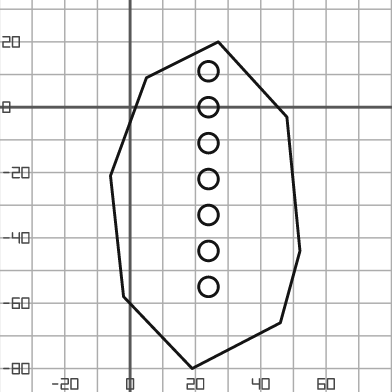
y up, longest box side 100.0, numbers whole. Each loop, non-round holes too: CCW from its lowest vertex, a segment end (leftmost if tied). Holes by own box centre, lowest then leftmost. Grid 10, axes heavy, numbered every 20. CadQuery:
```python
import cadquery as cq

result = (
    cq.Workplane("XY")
    .moveTo(19.0, -80.0)
    .lineTo(46.0, -66.0)
    .lineTo(52.0, -44.0)
    .lineTo(48.0, -3.0)
    .lineTo(27.0, 20.0)
    .lineTo(5.0, 9.0)
    .lineTo(-6.0, -21.0)
    .lineTo(-2.0, -58.0)
    .close()
    .moveTo(24.0, -55.0)
    .circle(3.0)
    .moveTo(24.0, -44.0)
    .circle(3.0)
    .moveTo(24.0, -33.0)
    .circle(3.0)
    .moveTo(24.0, -22.0)
    .circle(3.0)
    .moveTo(24.0, -11.0)
    .circle(3.0)
    .moveTo(24.0, 0.0)
    .circle(3.0)
    .moveTo(24.0, 11.0)
    .circle(3.0)
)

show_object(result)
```